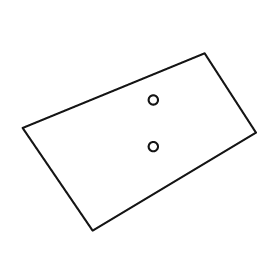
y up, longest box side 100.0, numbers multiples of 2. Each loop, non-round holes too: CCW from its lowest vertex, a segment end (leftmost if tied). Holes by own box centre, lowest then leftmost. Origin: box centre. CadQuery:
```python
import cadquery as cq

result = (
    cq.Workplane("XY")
    .moveTo(-20.0, -38.0)
    .lineTo(50.0, 4.0)
    .lineTo(28.0, 38.0)
    .lineTo(-50.0, 6.0)
    .close()
    .moveTo(6.0, -2.0)
    .circle(2.0)
    .moveTo(6.0, 18.0)
    .circle(2.0)
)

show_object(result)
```